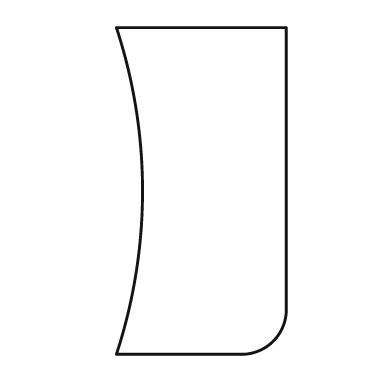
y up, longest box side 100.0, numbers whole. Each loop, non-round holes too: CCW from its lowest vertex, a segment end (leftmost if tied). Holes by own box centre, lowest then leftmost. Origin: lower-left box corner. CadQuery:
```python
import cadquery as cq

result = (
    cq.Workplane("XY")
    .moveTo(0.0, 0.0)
    .lineTo(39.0, 0.0)
    .threePointArc((48.0, 4.0), (52.0, 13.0))
    .lineTo(52.0, 100.0)
    .lineTo(0.0, 100.0)
    .threePointArc((8.0, 50.0), (0.0, 0.0))
    .close()
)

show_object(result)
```